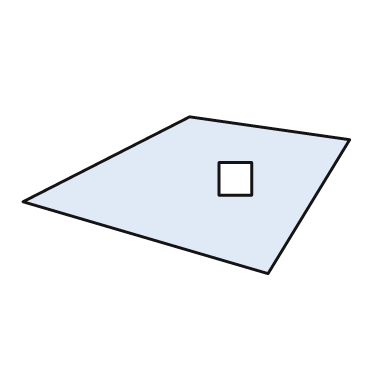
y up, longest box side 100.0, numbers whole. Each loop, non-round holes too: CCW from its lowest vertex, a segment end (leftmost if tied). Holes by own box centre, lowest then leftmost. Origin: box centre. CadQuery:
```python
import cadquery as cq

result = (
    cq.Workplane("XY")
    .moveTo(25.0, -24.0)
    .lineTo(50.0, 17.0)
    .lineTo(1.0, 24.0)
    .lineTo(-50.0, -2.0)
    .close()
    .moveTo(10.0, 0.0)
    .lineTo(20.0, 0.0)
    .lineTo(20.0, 10.0)
    .lineTo(10.0, 10.0)
    .close()
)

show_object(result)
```